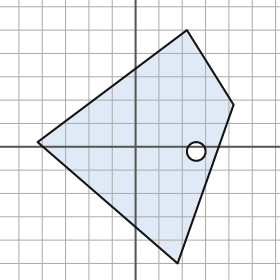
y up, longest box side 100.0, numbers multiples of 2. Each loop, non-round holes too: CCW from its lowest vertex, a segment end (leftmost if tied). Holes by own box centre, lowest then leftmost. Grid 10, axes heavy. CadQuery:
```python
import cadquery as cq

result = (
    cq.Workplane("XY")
    .moveTo(18.0, -50.0)
    .lineTo(42.0, 18.0)
    .lineTo(22.0, 50.0)
    .lineTo(-42.0, 2.0)
    .close()
    .moveTo(26.0, -2.0)
    .circle(4.0)
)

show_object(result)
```